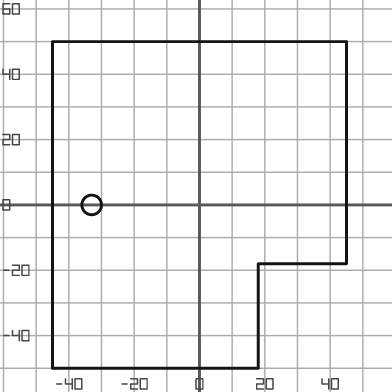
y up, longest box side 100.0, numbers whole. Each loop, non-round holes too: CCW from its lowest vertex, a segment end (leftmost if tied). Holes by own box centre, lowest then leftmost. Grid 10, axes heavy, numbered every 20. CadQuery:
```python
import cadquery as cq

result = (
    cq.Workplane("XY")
    .moveTo(-45.0, -50.0)
    .lineTo(18.0, -50.0)
    .lineTo(18.0, -18.0)
    .lineTo(45.0, -18.0)
    .lineTo(45.0, 50.0)
    .lineTo(-45.0, 50.0)
    .close()
    .moveTo(-33.0, 0.0)
    .circle(3.0)
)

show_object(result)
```